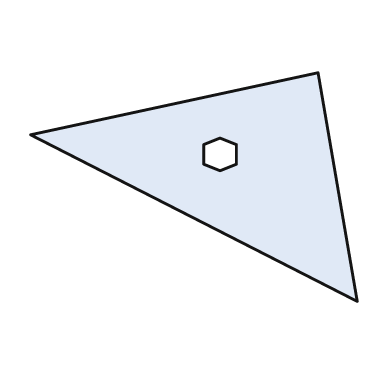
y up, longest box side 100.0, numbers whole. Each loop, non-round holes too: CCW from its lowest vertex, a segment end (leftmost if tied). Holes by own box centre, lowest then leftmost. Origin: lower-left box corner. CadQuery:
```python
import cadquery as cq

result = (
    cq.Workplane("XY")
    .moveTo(100.0, 0.0)
    .lineTo(88.0, 70.0)
    .lineTo(0.0, 51.0)
    .close()
    .moveTo(58.0, 40.0)
    .lineTo(63.0, 42.0)
    .lineTo(63.0, 48.0)
    .lineTo(58.0, 50.0)
    .lineTo(53.0, 48.0)
    .lineTo(53.0, 42.0)
    .close()
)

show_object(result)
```